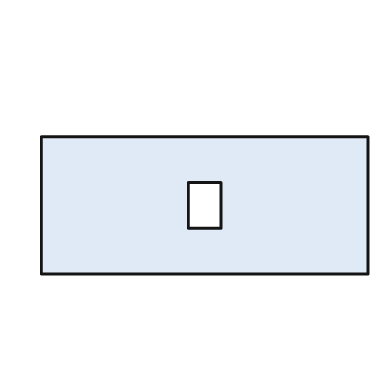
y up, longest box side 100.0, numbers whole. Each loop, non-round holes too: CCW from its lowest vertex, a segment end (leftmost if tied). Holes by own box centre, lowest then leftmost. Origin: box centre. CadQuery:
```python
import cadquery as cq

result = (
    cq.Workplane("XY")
    .moveTo(-50.0, -21.0)
    .lineTo(50.0, -21.0)
    .lineTo(50.0, 21.0)
    .lineTo(-50.0, 21.0)
    .close()
    .moveTo(-5.0, -7.0)
    .lineTo(5.0, -7.0)
    .lineTo(5.0, 7.0)
    .lineTo(-5.0, 7.0)
    .close()
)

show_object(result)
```